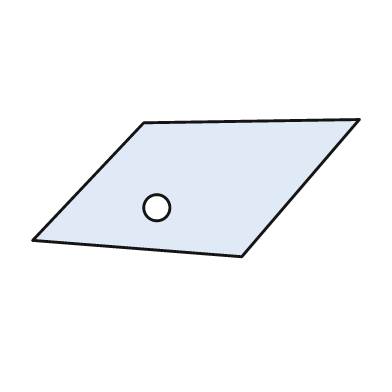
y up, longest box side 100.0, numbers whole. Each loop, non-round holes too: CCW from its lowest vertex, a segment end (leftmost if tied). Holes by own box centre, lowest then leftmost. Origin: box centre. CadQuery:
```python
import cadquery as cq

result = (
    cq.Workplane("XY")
    .moveTo(14.0, -21.0)
    .lineTo(50.0, 21.0)
    .lineTo(-16.0, 20.0)
    .lineTo(-50.0, -16.0)
    .close()
    .moveTo(-12.0, -6.0)
    .circle(4.0)
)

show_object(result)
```